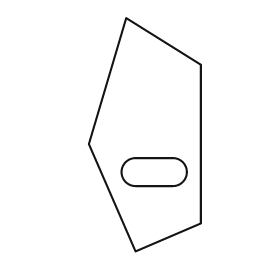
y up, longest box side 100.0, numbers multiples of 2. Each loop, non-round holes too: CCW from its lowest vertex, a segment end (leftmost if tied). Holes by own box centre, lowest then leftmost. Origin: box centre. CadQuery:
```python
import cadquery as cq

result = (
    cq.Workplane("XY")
    .moveTo(-4.0, -50.0)
    .lineTo(24.0, -38.0)
    .lineTo(24.0, 30.0)
    .lineTo(-8.0, 50.0)
    .lineTo(-24.0, -4.0)
    .close()
    .moveTo(-4.0, -22.0)
    .lineTo(12.0, -22.0)
    .threePointArc((18.0, -16.0), (12.0, -10.0))
    .lineTo(-4.0, -10.0)
    .threePointArc((-10.0, -16.0), (-4.0, -22.0))
    .close()
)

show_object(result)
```